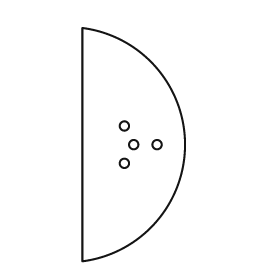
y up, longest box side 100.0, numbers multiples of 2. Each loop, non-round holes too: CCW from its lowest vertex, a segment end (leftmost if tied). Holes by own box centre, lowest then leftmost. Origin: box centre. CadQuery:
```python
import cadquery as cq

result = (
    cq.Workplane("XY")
    .moveTo(-22.0, -50.0)
    .threePointArc((22.0, 0.0), (-22.0, 50.0))
    .close()
    .moveTo(-4.0, -8.0)
    .circle(2.0)
    .moveTo(0.0, 0.0)
    .circle(2.0)
    .moveTo(10.0, 0.0)
    .circle(2.0)
    .moveTo(-4.0, 8.0)
    .circle(2.0)
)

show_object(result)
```